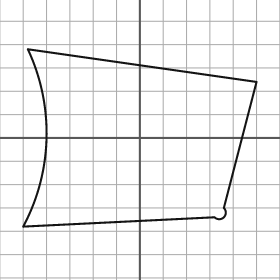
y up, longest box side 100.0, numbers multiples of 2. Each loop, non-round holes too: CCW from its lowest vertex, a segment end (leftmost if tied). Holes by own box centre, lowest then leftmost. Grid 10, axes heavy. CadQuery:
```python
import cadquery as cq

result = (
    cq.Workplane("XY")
    .moveTo(-50.0, -38.0)
    .lineTo(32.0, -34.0)
    .threePointArc((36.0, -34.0), (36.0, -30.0))
    .lineTo(50.0, 24.0)
    .lineTo(-48.0, 38.0)
    .threePointArc((-40.0, 0.0), (-50.0, -38.0))
    .close()
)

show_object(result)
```